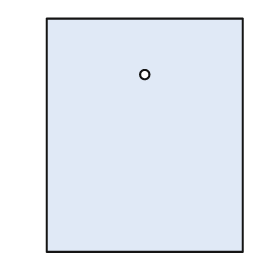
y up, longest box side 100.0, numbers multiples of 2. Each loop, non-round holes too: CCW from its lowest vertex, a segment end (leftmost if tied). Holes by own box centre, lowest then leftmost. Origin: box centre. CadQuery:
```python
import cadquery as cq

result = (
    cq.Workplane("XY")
    .moveTo(-42.0, -50.0)
    .lineTo(42.0, -50.0)
    .lineTo(42.0, 50.0)
    .lineTo(-42.0, 50.0)
    .close()
    .moveTo(0.0, 26.0)
    .circle(2.0)
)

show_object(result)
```